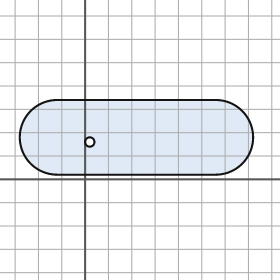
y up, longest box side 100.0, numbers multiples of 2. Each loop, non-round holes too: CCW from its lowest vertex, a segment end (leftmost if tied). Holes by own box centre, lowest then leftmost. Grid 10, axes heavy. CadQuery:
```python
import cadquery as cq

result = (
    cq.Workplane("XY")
    .moveTo(-12.0, 2.0)
    .lineTo(56.0, 2.0)
    .threePointArc((72.0, 18.0), (56.0, 34.0))
    .lineTo(-12.0, 34.0)
    .threePointArc((-28.0, 18.0), (-12.0, 2.0))
    .close()
    .moveTo(2.0, 16.0)
    .circle(2.0)
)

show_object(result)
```